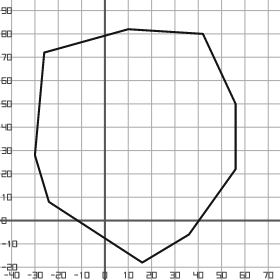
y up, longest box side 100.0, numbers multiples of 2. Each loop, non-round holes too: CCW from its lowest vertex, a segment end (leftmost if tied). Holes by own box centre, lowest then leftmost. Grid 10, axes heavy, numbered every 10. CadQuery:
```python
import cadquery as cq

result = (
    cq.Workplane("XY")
    .moveTo(16.0, -18.0)
    .lineTo(36.0, -6.0)
    .lineTo(56.0, 22.0)
    .lineTo(56.0, 50.0)
    .lineTo(42.0, 80.0)
    .lineTo(10.0, 82.0)
    .lineTo(-26.0, 72.0)
    .lineTo(-30.0, 28.0)
    .lineTo(-24.0, 8.0)
    .close()
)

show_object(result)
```